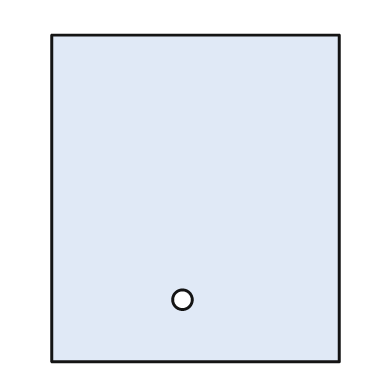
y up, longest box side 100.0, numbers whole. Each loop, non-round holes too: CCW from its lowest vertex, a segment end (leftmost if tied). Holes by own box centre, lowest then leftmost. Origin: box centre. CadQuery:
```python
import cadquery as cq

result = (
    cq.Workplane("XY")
    .moveTo(-44.0, -50.0)
    .lineTo(44.0, -50.0)
    .lineTo(44.0, 50.0)
    .lineTo(-44.0, 50.0)
    .close()
    .moveTo(-4.0, -31.0)
    .circle(3.0)
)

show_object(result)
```